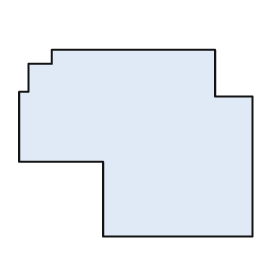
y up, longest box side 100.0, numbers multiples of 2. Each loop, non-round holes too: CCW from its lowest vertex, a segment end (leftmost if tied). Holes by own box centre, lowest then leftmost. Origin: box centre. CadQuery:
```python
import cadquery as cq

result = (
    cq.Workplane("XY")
    .moveTo(-14.0, -40.0)
    .lineTo(50.0, -40.0)
    .lineTo(50.0, 20.0)
    .lineTo(34.0, 20.0)
    .lineTo(34.0, 40.0)
    .lineTo(-36.0, 40.0)
    .lineTo(-36.0, 34.0)
    .lineTo(-46.0, 34.0)
    .lineTo(-46.0, 22.0)
    .lineTo(-50.0, 22.0)
    .lineTo(-50.0, -8.0)
    .lineTo(-14.0, -8.0)
    .close()
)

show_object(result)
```